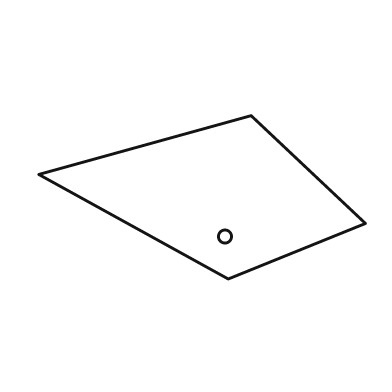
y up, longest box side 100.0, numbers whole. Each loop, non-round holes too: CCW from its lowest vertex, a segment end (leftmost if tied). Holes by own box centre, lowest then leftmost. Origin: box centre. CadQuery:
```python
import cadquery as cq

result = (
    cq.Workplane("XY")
    .moveTo(8.0, -25.0)
    .lineTo(50.0, -8.0)
    .lineTo(15.0, 25.0)
    .lineTo(-50.0, 7.0)
    .close()
    .moveTo(7.0, -12.0)
    .circle(2.0)
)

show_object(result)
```